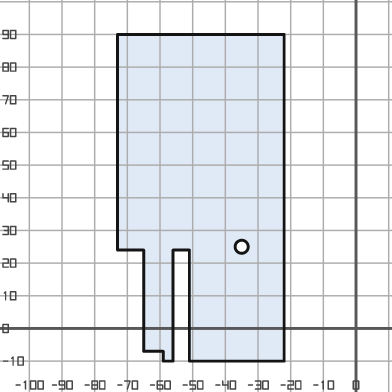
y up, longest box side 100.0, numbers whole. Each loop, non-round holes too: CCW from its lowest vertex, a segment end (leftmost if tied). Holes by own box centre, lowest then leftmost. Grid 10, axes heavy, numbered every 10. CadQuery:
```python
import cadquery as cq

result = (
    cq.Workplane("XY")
    .moveTo(-59.0, -10.0)
    .lineTo(-56.0, -10.0)
    .lineTo(-56.0, 24.0)
    .lineTo(-51.0, 24.0)
    .lineTo(-51.0, -10.0)
    .lineTo(-22.0, -10.0)
    .lineTo(-22.0, 90.0)
    .lineTo(-73.0, 90.0)
    .lineTo(-73.0, 24.0)
    .lineTo(-65.0, 24.0)
    .lineTo(-65.0, -7.0)
    .lineTo(-59.0, -7.0)
    .close()
    .moveTo(-35.0, 25.0)
    .circle(2.0)
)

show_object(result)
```